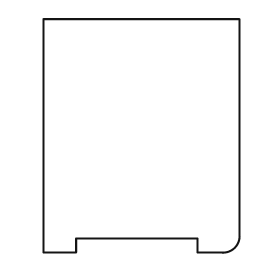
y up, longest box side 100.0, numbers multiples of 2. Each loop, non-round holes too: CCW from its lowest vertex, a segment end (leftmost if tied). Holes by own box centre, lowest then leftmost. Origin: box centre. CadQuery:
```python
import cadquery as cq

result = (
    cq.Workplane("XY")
    .moveTo(-42.0, -50.0)
    .lineTo(-28.0, -50.0)
    .lineTo(-28.0, -44.0)
    .lineTo(24.0, -44.0)
    .lineTo(24.0, -50.0)
    .lineTo(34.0, -50.0)
    .threePointArc((40.0, -48.0), (42.0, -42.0))
    .lineTo(42.0, 50.0)
    .lineTo(-42.0, 50.0)
    .close()
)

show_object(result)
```